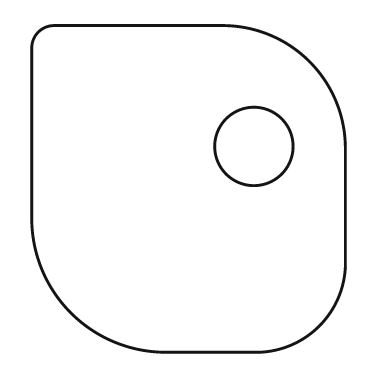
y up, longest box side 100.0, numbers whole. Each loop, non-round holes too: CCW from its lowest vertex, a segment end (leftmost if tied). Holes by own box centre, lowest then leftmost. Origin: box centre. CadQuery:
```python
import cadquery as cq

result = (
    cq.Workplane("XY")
    .moveTo(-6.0, -50.0)
    .lineTo(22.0, -50.0)
    .threePointArc((40.0, -42.0), (48.0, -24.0))
    .lineTo(48.0, 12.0)
    .threePointArc((37.0, 39.0), (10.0, 50.0))
    .lineTo(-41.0, 50.0)
    .threePointArc((-46.0, 48.0), (-48.0, 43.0))
    .lineTo(-48.0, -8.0)
    .threePointArc((-36.0, -38.0), (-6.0, -50.0))
    .close()
    .moveTo(20.0, 13.0)
    .circle(12.0)
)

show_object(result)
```